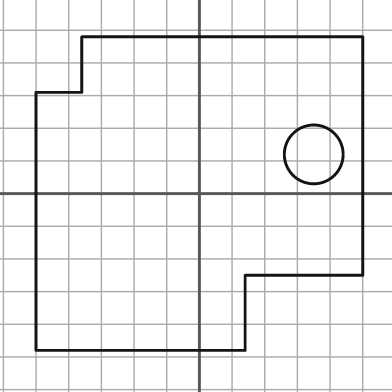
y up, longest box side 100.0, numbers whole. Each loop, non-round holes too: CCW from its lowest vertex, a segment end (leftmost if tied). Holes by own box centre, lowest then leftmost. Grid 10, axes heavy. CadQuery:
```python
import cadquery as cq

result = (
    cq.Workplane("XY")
    .moveTo(-50.0, -48.0)
    .lineTo(14.0, -48.0)
    .lineTo(14.0, -25.0)
    .lineTo(50.0, -25.0)
    .lineTo(50.0, 48.0)
    .lineTo(-36.0, 48.0)
    .lineTo(-36.0, 31.0)
    .lineTo(-50.0, 31.0)
    .close()
    .moveTo(35.0, 12.0)
    .circle(9.0)
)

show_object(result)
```